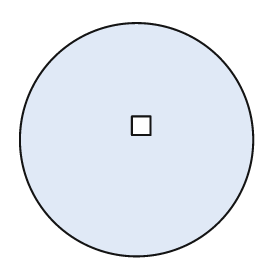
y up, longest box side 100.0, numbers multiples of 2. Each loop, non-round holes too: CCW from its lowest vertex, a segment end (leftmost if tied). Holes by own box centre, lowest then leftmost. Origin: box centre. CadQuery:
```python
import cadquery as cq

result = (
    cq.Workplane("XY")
    .moveTo(0.0, 0.0)
    .circle(50.0)
    .moveTo(-2.0, 2.0)
    .lineTo(6.0, 2.0)
    .lineTo(6.0, 10.0)
    .lineTo(-2.0, 10.0)
    .close()
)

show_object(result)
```